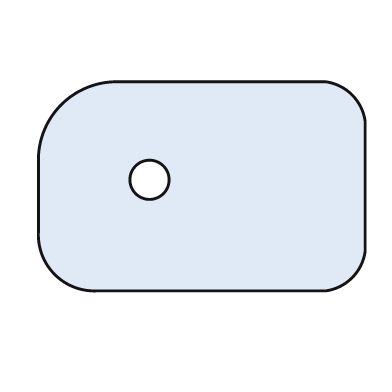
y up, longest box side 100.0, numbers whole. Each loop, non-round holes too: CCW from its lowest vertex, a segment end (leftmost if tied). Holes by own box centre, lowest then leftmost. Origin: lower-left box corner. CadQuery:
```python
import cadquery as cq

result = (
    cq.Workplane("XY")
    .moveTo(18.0, 0.0)
    .lineTo(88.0, 0.0)
    .threePointArc((96.0, 4.0), (100.0, 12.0))
    .lineTo(100.0, 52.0)
    .threePointArc((96.0, 60.0), (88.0, 64.0))
    .lineTo(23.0, 64.0)
    .threePointArc((7.0, 57.0), (0.0, 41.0))
    .lineTo(0.0, 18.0)
    .threePointArc((5.0, 5.0), (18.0, 0.0))
    .close()
    .moveTo(34.0, 34.0)
    .circle(6.0)
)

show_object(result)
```